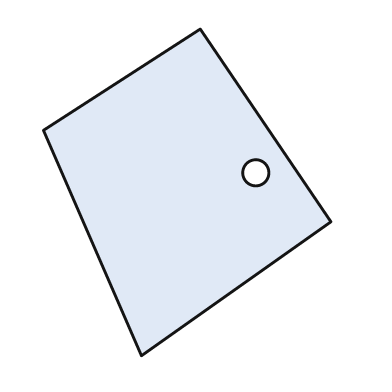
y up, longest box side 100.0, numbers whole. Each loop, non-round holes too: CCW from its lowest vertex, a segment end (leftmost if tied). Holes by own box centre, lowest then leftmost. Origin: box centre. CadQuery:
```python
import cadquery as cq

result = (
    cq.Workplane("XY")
    .moveTo(-14.0, -50.0)
    .lineTo(44.0, -9.0)
    .lineTo(4.0, 50.0)
    .lineTo(-44.0, 19.0)
    .close()
    .moveTo(21.0, 6.0)
    .circle(4.0)
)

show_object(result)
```